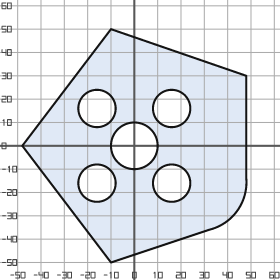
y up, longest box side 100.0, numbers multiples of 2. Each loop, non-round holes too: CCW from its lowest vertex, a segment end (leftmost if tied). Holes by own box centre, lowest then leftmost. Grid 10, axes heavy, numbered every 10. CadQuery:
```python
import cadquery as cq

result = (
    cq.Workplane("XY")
    .moveTo(-10.0, -50.0)
    .lineTo(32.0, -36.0)
    .threePointArc((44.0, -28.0), (48.0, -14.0))
    .lineTo(48.0, 30.0)
    .lineTo(-10.0, 50.0)
    .lineTo(-48.0, 0.0)
    .close()
    .moveTo(-16.0, -16.0)
    .circle(8.0)
    .moveTo(16.0, -16.0)
    .circle(8.0)
    .moveTo(0.0, 0.0)
    .circle(10.0)
    .moveTo(-16.0, 16.0)
    .circle(8.0)
    .moveTo(16.0, 16.0)
    .circle(8.0)
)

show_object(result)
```